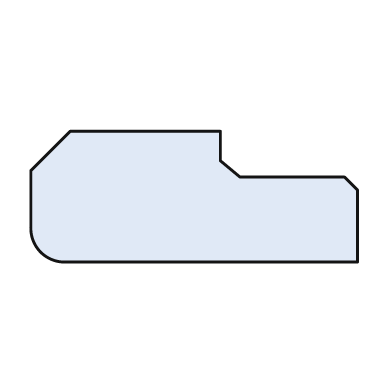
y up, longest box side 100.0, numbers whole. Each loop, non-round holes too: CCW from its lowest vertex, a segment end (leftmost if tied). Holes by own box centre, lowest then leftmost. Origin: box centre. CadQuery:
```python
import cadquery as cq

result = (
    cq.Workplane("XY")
    .moveTo(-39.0, -20.0)
    .lineTo(50.0, -20.0)
    .lineTo(50.0, 2.0)
    .lineTo(46.0, 6.0)
    .lineTo(14.0, 6.0)
    .lineTo(8.0, 11.0)
    .lineTo(8.0, 20.0)
    .lineTo(-38.0, 20.0)
    .lineTo(-50.0, 8.0)
    .lineTo(-50.0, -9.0)
    .threePointArc((-47.0, -17.0), (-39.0, -20.0))
    .close()
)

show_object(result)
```